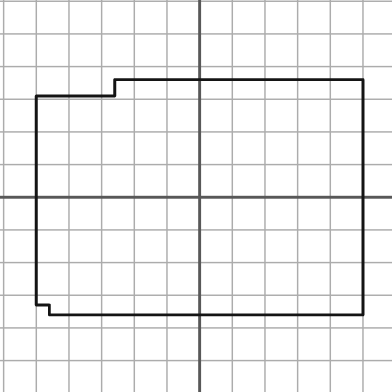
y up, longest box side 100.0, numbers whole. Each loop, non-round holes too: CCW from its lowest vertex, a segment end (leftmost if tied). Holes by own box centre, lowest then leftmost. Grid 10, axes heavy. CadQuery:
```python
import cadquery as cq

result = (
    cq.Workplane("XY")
    .moveTo(-46.0, -36.0)
    .lineTo(50.0, -36.0)
    .lineTo(50.0, 36.0)
    .lineTo(-26.0, 36.0)
    .lineTo(-26.0, 31.0)
    .lineTo(-50.0, 31.0)
    .lineTo(-50.0, -33.0)
    .lineTo(-46.0, -33.0)
    .close()
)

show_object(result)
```